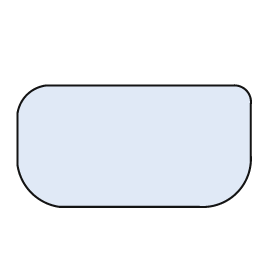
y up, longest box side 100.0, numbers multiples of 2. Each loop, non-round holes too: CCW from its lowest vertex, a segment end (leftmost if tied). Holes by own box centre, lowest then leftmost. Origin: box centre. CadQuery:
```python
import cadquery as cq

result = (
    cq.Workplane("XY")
    .moveTo(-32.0, -26.0)
    .lineTo(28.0, -26.0)
    .threePointArc((44.0, -20.0), (50.0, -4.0))
    .lineTo(50.0, 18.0)
    .threePointArc((48.0, 24.0), (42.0, 26.0))
    .lineTo(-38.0, 26.0)
    .threePointArc((-46.0, 22.0), (-50.0, 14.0))
    .lineTo(-50.0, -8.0)
    .threePointArc((-44.0, -20.0), (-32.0, -26.0))
    .close()
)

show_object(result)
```